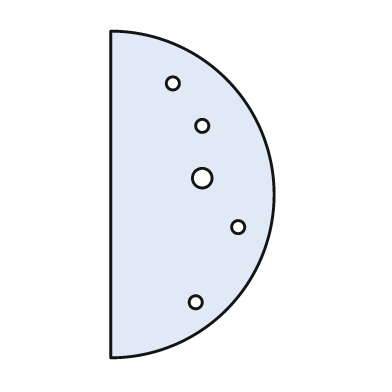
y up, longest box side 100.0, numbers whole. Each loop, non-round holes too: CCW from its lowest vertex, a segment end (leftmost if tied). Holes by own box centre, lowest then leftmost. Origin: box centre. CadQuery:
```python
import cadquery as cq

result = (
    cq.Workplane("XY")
    .moveTo(-25.0, -50.0)
    .threePointArc((25.0, 0.0), (-25.0, 50.0))
    .close()
    .moveTo(1.0, -33.0)
    .circle(2.0)
    .moveTo(14.0, -10.0)
    .circle(2.0)
    .moveTo(3.0, 5.0)
    .circle(3.0)
    .moveTo(3.0, 21.0)
    .circle(2.0)
    .moveTo(-6.0, 34.0)
    .circle(2.0)
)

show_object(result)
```